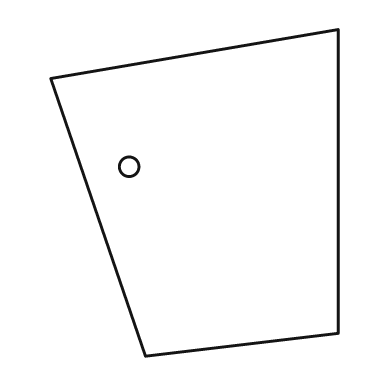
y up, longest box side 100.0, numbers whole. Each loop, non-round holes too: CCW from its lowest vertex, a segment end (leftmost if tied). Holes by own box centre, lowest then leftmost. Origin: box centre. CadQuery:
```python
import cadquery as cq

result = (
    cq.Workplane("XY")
    .moveTo(-15.0, -50.0)
    .lineTo(44.0, -43.0)
    .lineTo(44.0, 50.0)
    .lineTo(-44.0, 35.0)
    .close()
    .moveTo(-20.0, 8.0)
    .circle(3.0)
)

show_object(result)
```